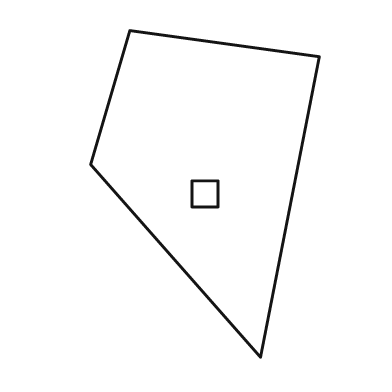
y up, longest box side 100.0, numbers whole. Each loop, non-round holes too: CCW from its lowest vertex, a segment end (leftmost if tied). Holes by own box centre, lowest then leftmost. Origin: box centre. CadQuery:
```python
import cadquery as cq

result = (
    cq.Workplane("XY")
    .moveTo(17.0, -50.0)
    .lineTo(35.0, 42.0)
    .lineTo(-23.0, 50.0)
    .lineTo(-35.0, 9.0)
    .close()
    .moveTo(-4.0, -4.0)
    .lineTo(4.0, -4.0)
    .lineTo(4.0, 4.0)
    .lineTo(-4.0, 4.0)
    .close()
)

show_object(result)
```